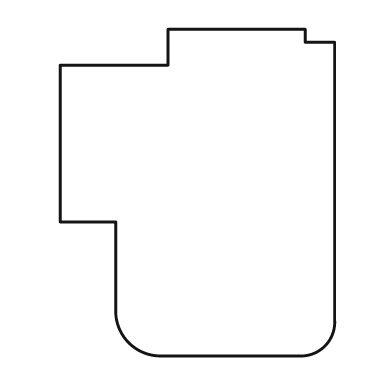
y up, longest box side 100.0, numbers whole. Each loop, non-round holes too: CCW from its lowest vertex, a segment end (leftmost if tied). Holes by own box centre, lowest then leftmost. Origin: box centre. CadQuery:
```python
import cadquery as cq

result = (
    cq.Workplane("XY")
    .moveTo(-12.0, -50.0)
    .lineTo(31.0, -50.0)
    .threePointArc((39.0, -47.0), (42.0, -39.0))
    .lineTo(42.0, 46.0)
    .lineTo(33.0, 46.0)
    .lineTo(33.0, 50.0)
    .lineTo(-9.0, 50.0)
    .lineTo(-9.0, 39.0)
    .lineTo(-42.0, 39.0)
    .lineTo(-42.0, -9.0)
    .lineTo(-25.0, -9.0)
    .lineTo(-25.0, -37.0)
    .threePointArc((-21.0, -46.0), (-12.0, -50.0))
    .close()
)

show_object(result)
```